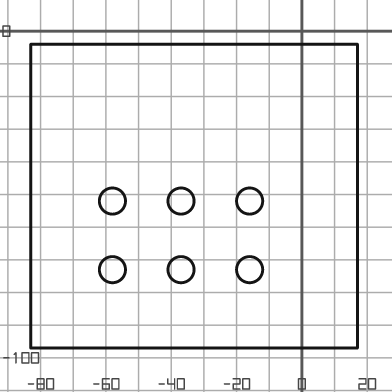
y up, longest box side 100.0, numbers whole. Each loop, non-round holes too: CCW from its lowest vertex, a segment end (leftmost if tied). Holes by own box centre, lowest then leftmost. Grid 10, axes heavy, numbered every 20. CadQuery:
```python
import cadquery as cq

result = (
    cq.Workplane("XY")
    .moveTo(-83.0, -97.0)
    .lineTo(17.0, -97.0)
    .lineTo(17.0, -4.0)
    .lineTo(-83.0, -4.0)
    .close()
    .moveTo(-58.0, -73.0)
    .circle(4.0)
    .moveTo(-37.0, -73.0)
    .circle(4.0)
    .moveTo(-16.0, -73.0)
    .circle(4.0)
    .moveTo(-58.0, -52.0)
    .circle(4.0)
    .moveTo(-37.0, -52.0)
    .circle(4.0)
    .moveTo(-16.0, -52.0)
    .circle(4.0)
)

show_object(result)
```